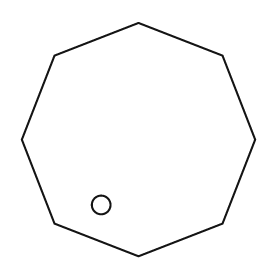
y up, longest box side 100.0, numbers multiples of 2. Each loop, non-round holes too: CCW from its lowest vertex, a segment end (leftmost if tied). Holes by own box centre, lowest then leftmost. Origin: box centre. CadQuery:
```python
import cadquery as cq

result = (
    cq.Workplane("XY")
    .moveTo(0.0, -50.0)
    .lineTo(36.0, -36.0)
    .lineTo(50.0, 0.0)
    .lineTo(36.0, 36.0)
    .lineTo(0.0, 50.0)
    .lineTo(-36.0, 36.0)
    .lineTo(-50.0, 0.0)
    .lineTo(-36.0, -36.0)
    .close()
    .moveTo(-16.0, -28.0)
    .circle(4.0)
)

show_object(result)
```